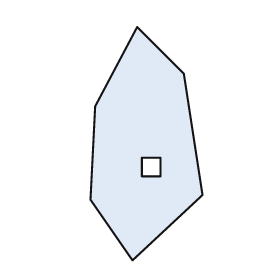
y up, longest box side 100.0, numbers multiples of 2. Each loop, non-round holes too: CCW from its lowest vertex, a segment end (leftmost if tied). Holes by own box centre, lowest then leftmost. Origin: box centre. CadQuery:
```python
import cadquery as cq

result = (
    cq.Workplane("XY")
    .moveTo(-6.0, -50.0)
    .lineTo(24.0, -22.0)
    .lineTo(16.0, 30.0)
    .lineTo(-4.0, 50.0)
    .lineTo(-22.0, 16.0)
    .lineTo(-24.0, -24.0)
    .close()
    .moveTo(-2.0, -14.0)
    .lineTo(6.0, -14.0)
    .lineTo(6.0, -6.0)
    .lineTo(-2.0, -6.0)
    .close()
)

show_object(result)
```